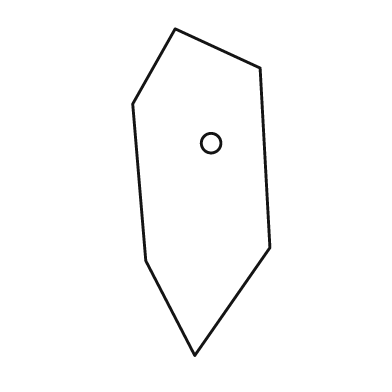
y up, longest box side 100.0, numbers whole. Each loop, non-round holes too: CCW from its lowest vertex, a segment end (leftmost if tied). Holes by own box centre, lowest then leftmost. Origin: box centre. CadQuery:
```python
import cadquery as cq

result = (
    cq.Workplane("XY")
    .moveTo(-2.0, -50.0)
    .lineTo(21.0, -17.0)
    .lineTo(18.0, 38.0)
    .lineTo(-8.0, 50.0)
    .lineTo(-21.0, 27.0)
    .lineTo(-17.0, -21.0)
    .close()
    .moveTo(3.0, 15.0)
    .circle(3.0)
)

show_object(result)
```